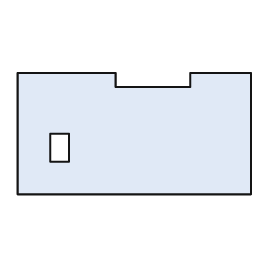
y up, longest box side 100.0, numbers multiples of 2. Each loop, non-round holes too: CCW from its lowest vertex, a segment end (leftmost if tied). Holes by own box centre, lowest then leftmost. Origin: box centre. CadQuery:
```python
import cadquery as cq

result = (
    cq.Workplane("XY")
    .moveTo(-50.0, -26.0)
    .lineTo(50.0, -26.0)
    .lineTo(50.0, 26.0)
    .lineTo(24.0, 26.0)
    .lineTo(24.0, 20.0)
    .lineTo(-8.0, 20.0)
    .lineTo(-8.0, 26.0)
    .lineTo(-50.0, 26.0)
    .close()
    .moveTo(-36.0, -12.0)
    .lineTo(-28.0, -12.0)
    .lineTo(-28.0, 0.0)
    .lineTo(-36.0, 0.0)
    .close()
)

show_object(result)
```